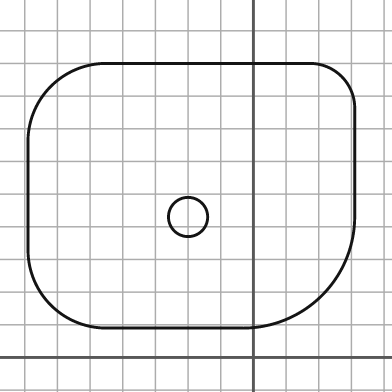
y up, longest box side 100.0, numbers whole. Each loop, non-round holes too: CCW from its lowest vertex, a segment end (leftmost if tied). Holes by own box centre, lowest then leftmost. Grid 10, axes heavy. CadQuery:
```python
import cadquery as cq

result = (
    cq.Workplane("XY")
    .moveTo(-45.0, 9.0)
    .lineTo(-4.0, 9.0)
    .threePointArc((21.0, 19.0), (31.0, 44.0))
    .lineTo(31.0, 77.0)
    .threePointArc((27.0, 86.0), (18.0, 90.0))
    .lineTo(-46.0, 90.0)
    .threePointArc((-62.0, 83.0), (-69.0, 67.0))
    .lineTo(-69.0, 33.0)
    .threePointArc((-62.0, 16.0), (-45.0, 9.0))
    .close()
    .moveTo(-20.0, 43.0)
    .circle(6.0)
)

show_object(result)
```